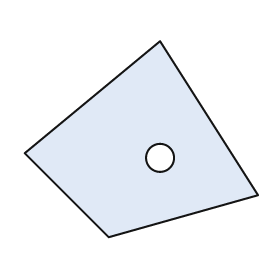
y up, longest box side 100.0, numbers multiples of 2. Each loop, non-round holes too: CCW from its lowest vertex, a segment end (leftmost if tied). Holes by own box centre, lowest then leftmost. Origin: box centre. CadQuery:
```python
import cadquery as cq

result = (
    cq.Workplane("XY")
    .moveTo(-14.0, -42.0)
    .lineTo(50.0, -24.0)
    .lineTo(8.0, 42.0)
    .lineTo(-50.0, -6.0)
    .close()
    .moveTo(8.0, -8.0)
    .circle(6.0)
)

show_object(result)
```